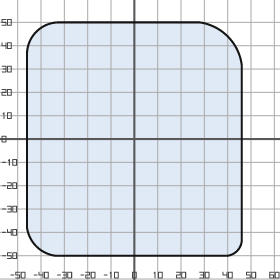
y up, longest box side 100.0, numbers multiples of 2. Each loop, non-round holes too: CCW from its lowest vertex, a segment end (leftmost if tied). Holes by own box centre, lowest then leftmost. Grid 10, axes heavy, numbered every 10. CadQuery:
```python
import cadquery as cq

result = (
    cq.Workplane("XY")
    .moveTo(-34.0, -50.0)
    .lineTo(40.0, -50.0)
    .threePointArc((44.0, -48.0), (46.0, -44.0))
    .lineTo(46.0, 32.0)
    .threePointArc((40.0, 44.0), (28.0, 50.0))
    .lineTo(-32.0, 50.0)
    .threePointArc((-42.0, 46.0), (-46.0, 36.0))
    .lineTo(-46.0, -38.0)
    .threePointArc((-42.0, -46.0), (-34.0, -50.0))
    .close()
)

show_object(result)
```